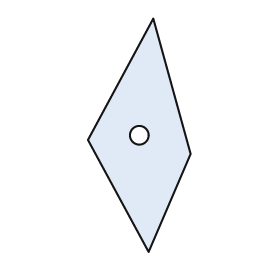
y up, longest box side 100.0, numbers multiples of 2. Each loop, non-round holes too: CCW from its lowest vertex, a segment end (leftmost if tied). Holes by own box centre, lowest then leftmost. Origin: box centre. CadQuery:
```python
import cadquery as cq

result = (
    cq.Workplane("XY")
    .moveTo(4.0, -50.0)
    .lineTo(22.0, -8.0)
    .lineTo(6.0, 50.0)
    .lineTo(-22.0, -2.0)
    .close()
    .moveTo(0.0, 0.0)
    .circle(4.0)
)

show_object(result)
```